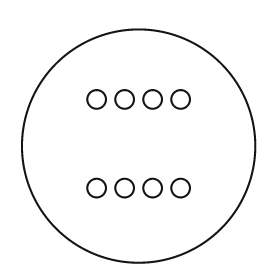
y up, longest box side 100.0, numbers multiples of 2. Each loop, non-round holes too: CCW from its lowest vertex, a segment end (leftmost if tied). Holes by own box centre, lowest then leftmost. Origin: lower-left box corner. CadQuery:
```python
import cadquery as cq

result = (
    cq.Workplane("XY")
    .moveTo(50.0, 50.0)
    .circle(50.0)
    .moveTo(32.0, 32.0)
    .circle(4.0)
    .moveTo(44.0, 32.0)
    .circle(4.0)
    .moveTo(56.0, 32.0)
    .circle(4.0)
    .moveTo(68.0, 32.0)
    .circle(4.0)
    .moveTo(32.0, 70.0)
    .circle(4.0)
    .moveTo(44.0, 70.0)
    .circle(4.0)
    .moveTo(56.0, 70.0)
    .circle(4.0)
    .moveTo(68.0, 70.0)
    .circle(4.0)
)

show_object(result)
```